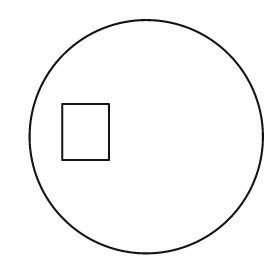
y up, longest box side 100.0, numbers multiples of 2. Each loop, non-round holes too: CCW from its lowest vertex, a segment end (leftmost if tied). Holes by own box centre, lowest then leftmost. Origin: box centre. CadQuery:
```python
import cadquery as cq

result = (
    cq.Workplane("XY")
    .moveTo(0.0, 0.0)
    .circle(50.0)
    .moveTo(-36.0, -10.0)
    .lineTo(-16.0, -10.0)
    .lineTo(-16.0, 14.0)
    .lineTo(-36.0, 14.0)
    .close()
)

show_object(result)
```